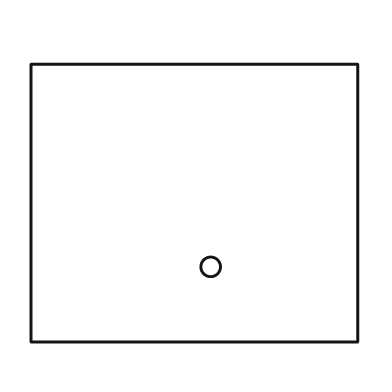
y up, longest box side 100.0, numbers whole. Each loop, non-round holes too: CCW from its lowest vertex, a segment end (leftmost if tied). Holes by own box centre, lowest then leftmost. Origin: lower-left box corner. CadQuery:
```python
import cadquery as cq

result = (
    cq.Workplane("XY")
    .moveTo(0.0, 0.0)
    .lineTo(100.0, 0.0)
    .lineTo(100.0, 85.0)
    .lineTo(0.0, 85.0)
    .close()
    .moveTo(55.0, 23.0)
    .circle(3.0)
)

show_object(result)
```